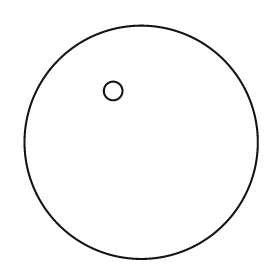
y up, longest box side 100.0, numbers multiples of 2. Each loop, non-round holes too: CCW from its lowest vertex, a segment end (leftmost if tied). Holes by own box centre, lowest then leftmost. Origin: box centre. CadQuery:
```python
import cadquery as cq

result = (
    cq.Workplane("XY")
    .moveTo(0.0, 0.0)
    .circle(50.0)
    .moveTo(-12.0, 22.0)
    .circle(4.0)
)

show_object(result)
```